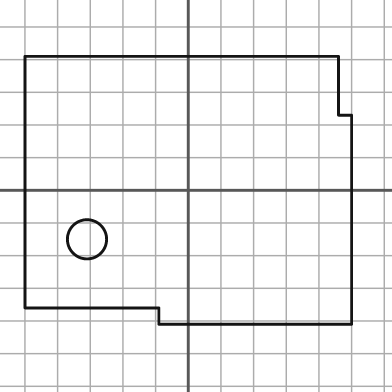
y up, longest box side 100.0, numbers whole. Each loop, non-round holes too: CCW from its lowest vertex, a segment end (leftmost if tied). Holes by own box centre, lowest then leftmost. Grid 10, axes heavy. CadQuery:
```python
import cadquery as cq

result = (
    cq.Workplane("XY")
    .moveTo(-9.0, -41.0)
    .lineTo(50.0, -41.0)
    .lineTo(50.0, 23.0)
    .lineTo(46.0, 23.0)
    .lineTo(46.0, 41.0)
    .lineTo(-50.0, 41.0)
    .lineTo(-50.0, -36.0)
    .lineTo(-9.0, -36.0)
    .close()
    .moveTo(-31.0, -15.0)
    .circle(6.0)
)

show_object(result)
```